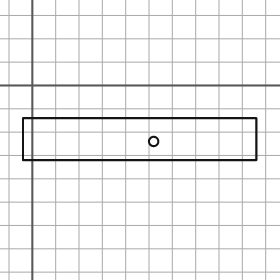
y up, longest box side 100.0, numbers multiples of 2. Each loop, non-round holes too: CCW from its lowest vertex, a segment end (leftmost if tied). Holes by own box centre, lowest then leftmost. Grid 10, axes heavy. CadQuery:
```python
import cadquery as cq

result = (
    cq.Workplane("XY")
    .moveTo(-4.0, -32.0)
    .lineTo(96.0, -32.0)
    .lineTo(96.0, -14.0)
    .lineTo(-4.0, -14.0)
    .close()
    .moveTo(52.0, -24.0)
    .circle(2.0)
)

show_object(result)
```